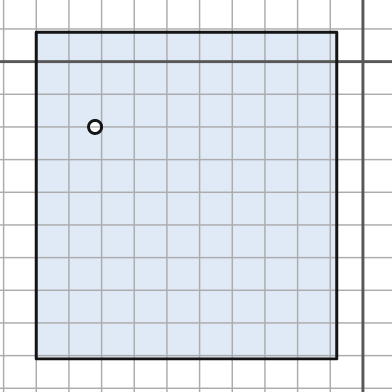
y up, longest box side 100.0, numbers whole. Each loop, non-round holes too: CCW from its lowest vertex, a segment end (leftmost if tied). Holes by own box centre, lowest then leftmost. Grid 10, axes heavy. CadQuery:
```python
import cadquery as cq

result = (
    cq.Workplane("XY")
    .moveTo(-100.0, -91.0)
    .lineTo(-8.0, -91.0)
    .lineTo(-8.0, 9.0)
    .lineTo(-100.0, 9.0)
    .close()
    .moveTo(-82.0, -20.0)
    .circle(2.0)
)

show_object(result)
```